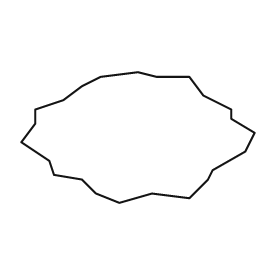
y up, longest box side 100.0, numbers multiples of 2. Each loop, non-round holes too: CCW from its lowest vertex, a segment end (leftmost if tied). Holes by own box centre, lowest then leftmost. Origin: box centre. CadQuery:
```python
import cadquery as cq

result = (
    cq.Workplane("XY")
    .moveTo(-8.0, -28.0)
    .lineTo(6.0, -24.0)
    .lineTo(22.0, -26.0)
    .lineTo(30.0, -18.0)
    .lineTo(32.0, -14.0)
    .lineTo(46.0, -6.0)
    .lineTo(50.0, 2.0)
    .lineTo(40.0, 8.0)
    .lineTo(40.0, 12.0)
    .lineTo(28.0, 18.0)
    .lineTo(22.0, 26.0)
    .lineTo(8.0, 26.0)
    .lineTo(0.0, 28.0)
    .lineTo(-16.0, 26.0)
    .lineTo(-24.0, 22.0)
    .lineTo(-32.0, 16.0)
    .lineTo(-44.0, 12.0)
    .lineTo(-44.0, 6.0)
    .lineTo(-50.0, -2.0)
    .lineTo(-38.0, -10.0)
    .lineTo(-36.0, -16.0)
    .lineTo(-24.0, -18.0)
    .lineTo(-18.0, -24.0)
    .close()
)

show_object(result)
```